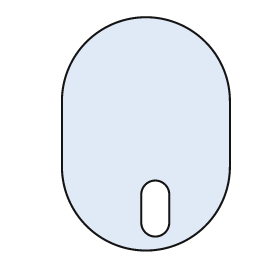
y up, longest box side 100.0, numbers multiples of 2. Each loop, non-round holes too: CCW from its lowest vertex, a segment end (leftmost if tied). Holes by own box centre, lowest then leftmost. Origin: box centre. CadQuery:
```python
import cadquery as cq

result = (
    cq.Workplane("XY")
    .moveTo(-36.0, -14.0)
    .threePointArc((0.0, -50.0), (36.0, -14.0))
    .lineTo(36.0, 14.0)
    .threePointArc((0.0, 50.0), (-36.0, 14.0))
    .close()
    .moveTo(-2.0, -38.0)
    .threePointArc((4.0, -44.0), (10.0, -38.0))
    .lineTo(10.0, -26.0)
    .threePointArc((4.0, -20.0), (-2.0, -26.0))
    .close()
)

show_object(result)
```